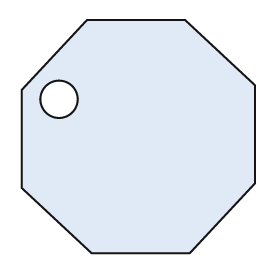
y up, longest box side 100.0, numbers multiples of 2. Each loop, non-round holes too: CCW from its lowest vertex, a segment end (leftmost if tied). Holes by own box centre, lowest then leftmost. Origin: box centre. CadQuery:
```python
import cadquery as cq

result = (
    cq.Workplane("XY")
    .moveTo(-20.0, -50.0)
    .lineTo(22.0, -50.0)
    .lineTo(50.0, -20.0)
    .lineTo(50.0, 22.0)
    .lineTo(20.0, 50.0)
    .lineTo(-22.0, 50.0)
    .lineTo(-50.0, 20.0)
    .lineTo(-50.0, -22.0)
    .close()
    .moveTo(-34.0, 16.0)
    .circle(8.0)
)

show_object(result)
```